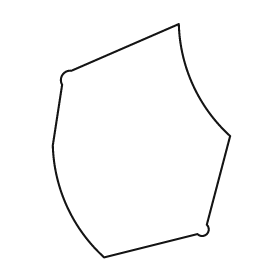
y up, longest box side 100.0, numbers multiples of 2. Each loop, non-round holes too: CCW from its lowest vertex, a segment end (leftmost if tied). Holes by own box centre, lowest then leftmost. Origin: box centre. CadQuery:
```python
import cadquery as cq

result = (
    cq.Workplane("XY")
    .moveTo(-16.0, -50.0)
    .lineTo(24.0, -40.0)
    .threePointArc((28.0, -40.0), (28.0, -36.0))
    .lineTo(38.0, 2.0)
    .threePointArc((22.0, 24.0), (16.0, 50.0))
    .lineTo(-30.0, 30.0)
    .threePointArc((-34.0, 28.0), (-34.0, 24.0))
    .lineTo(-38.0, -2.0)
    .threePointArc((-32.0, -28.0), (-16.0, -50.0))
    .close()
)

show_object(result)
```